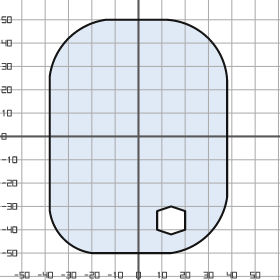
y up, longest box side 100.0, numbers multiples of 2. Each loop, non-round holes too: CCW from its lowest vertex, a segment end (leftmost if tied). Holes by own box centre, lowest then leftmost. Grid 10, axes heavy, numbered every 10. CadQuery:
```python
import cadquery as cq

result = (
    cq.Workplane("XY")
    .moveTo(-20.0, -50.0)
    .lineTo(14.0, -50.0)
    .threePointArc((30.0, -42.0), (38.0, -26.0))
    .lineTo(38.0, 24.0)
    .threePointArc((30.0, 42.0), (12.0, 50.0))
    .lineTo(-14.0, 50.0)
    .threePointArc((-30.0, 42.0), (-38.0, 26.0))
    .lineTo(-38.0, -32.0)
    .threePointArc((-32.0, -44.0), (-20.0, -50.0))
    .close()
    .moveTo(14.0, -42.0)
    .lineTo(20.0, -40.0)
    .lineTo(20.0, -32.0)
    .lineTo(14.0, -30.0)
    .lineTo(8.0, -32.0)
    .lineTo(8.0, -40.0)
    .close()
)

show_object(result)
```